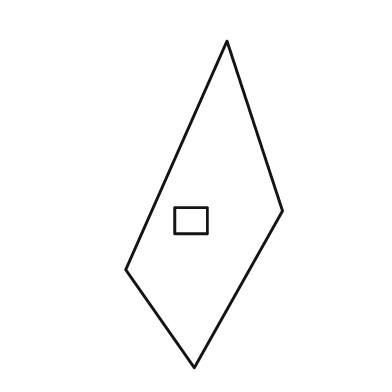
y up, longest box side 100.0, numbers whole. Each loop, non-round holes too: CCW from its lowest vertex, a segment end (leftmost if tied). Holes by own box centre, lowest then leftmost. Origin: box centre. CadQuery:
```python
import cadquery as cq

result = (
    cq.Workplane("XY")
    .moveTo(-3.0, -50.0)
    .lineTo(24.0, -2.0)
    .lineTo(7.0, 50.0)
    .lineTo(-24.0, -20.0)
    .close()
    .moveTo(-9.0, -9.0)
    .lineTo(1.0, -9.0)
    .lineTo(1.0, -1.0)
    .lineTo(-9.0, -1.0)
    .close()
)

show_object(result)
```